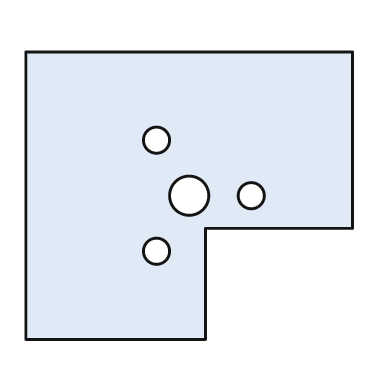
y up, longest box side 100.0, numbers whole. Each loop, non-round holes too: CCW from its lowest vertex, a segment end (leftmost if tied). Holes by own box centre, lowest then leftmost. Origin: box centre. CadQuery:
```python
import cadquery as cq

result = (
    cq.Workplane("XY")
    .moveTo(-50.0, -44.0)
    .lineTo(5.0, -44.0)
    .lineTo(5.0, -10.0)
    .lineTo(50.0, -10.0)
    .lineTo(50.0, 44.0)
    .lineTo(-50.0, 44.0)
    .close()
    .moveTo(-10.0, -17.0)
    .circle(4.0)
    .moveTo(0.0, 0.0)
    .circle(6.0)
    .moveTo(19.0, 0.0)
    .circle(4.0)
    .moveTo(-10.0, 17.0)
    .circle(4.0)
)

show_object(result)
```